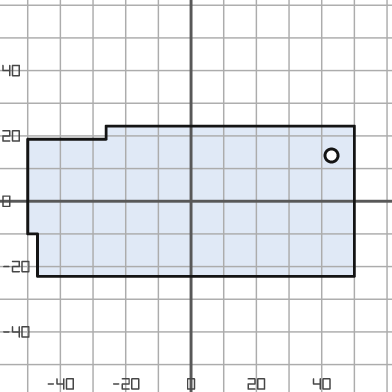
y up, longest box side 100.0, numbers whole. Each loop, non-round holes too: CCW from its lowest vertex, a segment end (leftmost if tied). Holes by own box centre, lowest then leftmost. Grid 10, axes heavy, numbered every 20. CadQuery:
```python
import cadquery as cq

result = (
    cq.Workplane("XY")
    .moveTo(-47.0, -23.0)
    .lineTo(50.0, -23.0)
    .lineTo(50.0, 23.0)
    .lineTo(-26.0, 23.0)
    .lineTo(-26.0, 19.0)
    .lineTo(-50.0, 19.0)
    .lineTo(-50.0, -10.0)
    .lineTo(-47.0, -10.0)
    .close()
    .moveTo(43.0, 14.0)
    .circle(2.0)
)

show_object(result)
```